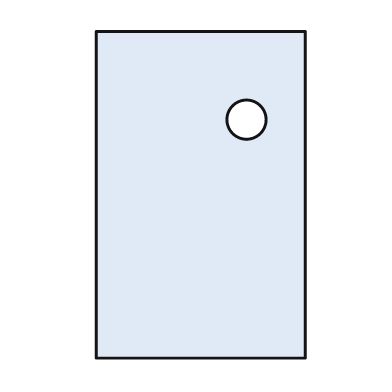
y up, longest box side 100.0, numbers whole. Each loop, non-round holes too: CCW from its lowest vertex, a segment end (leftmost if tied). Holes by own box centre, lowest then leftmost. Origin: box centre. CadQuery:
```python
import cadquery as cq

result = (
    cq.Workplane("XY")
    .moveTo(-32.0, -50.0)
    .lineTo(32.0, -50.0)
    .lineTo(32.0, 50.0)
    .lineTo(-32.0, 50.0)
    .close()
    .moveTo(14.0, 23.0)
    .circle(6.0)
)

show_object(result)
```